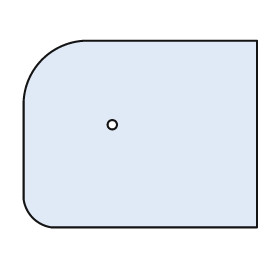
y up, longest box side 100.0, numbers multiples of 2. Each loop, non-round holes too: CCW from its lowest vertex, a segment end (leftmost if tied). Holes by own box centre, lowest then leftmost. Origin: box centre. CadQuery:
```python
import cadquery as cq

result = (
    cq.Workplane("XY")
    .moveTo(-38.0, -40.0)
    .lineTo(50.0, -40.0)
    .lineTo(50.0, 40.0)
    .lineTo(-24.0, 40.0)
    .threePointArc((-42.0, 32.0), (-50.0, 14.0))
    .lineTo(-50.0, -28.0)
    .threePointArc((-46.0, -36.0), (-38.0, -40.0))
    .close()
    .moveTo(-12.0, 4.0)
    .circle(2.0)
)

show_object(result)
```